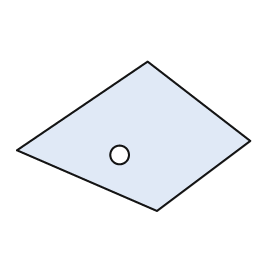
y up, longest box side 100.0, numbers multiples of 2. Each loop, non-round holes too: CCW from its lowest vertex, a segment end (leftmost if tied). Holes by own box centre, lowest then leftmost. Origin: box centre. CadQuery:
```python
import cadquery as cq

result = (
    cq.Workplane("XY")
    .moveTo(10.0, -32.0)
    .lineTo(50.0, -2.0)
    .lineTo(6.0, 32.0)
    .lineTo(-50.0, -6.0)
    .close()
    .moveTo(-6.0, -8.0)
    .circle(4.0)
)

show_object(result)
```